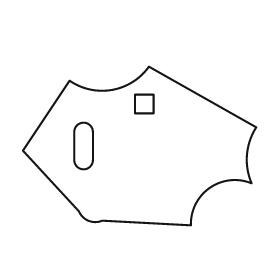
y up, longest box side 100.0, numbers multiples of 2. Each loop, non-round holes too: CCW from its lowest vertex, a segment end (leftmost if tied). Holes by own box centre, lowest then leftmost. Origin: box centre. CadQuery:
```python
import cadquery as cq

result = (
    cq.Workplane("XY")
    .moveTo(22.0, -34.0)
    .threePointArc((30.0, -18.0), (48.0, -16.0))
    .threePointArc((46.0, -4.0), (50.0, 8.0))
    .lineTo(4.0, 34.0)
    .threePointArc((-12.0, 24.0), (-30.0, 28.0))
    .lineTo(-50.0, -2.0)
    .lineTo(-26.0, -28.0)
    .threePointArc((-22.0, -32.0), (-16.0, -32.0))
    .close()
    .moveTo(-28.0, -6.0)
    .threePointArc((-24.0, -10.0), (-20.0, -6.0))
    .lineTo(-20.0, 6.0)
    .threePointArc((-24.0, 10.0), (-28.0, 6.0))
    .close()
    .moveTo(-2.0, 14.0)
    .lineTo(6.0, 14.0)
    .lineTo(6.0, 22.0)
    .lineTo(-2.0, 22.0)
    .close()
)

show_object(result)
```